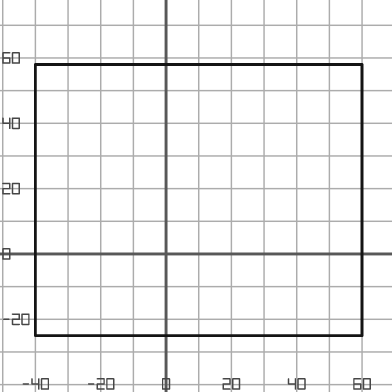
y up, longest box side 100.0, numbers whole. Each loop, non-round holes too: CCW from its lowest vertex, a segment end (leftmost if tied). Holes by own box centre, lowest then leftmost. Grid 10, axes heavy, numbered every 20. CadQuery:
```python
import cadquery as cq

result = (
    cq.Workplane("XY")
    .moveTo(-40.0, -25.0)
    .lineTo(60.0, -25.0)
    .lineTo(60.0, 58.0)
    .lineTo(-40.0, 58.0)
    .close()
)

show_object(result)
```